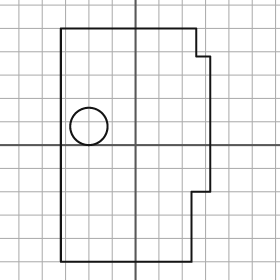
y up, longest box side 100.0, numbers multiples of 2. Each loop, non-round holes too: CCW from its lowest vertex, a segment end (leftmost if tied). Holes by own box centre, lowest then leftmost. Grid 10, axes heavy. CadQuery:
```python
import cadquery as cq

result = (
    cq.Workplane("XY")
    .moveTo(-32.0, -50.0)
    .lineTo(24.0, -50.0)
    .lineTo(24.0, -20.0)
    .lineTo(32.0, -20.0)
    .lineTo(32.0, 38.0)
    .lineTo(26.0, 38.0)
    .lineTo(26.0, 50.0)
    .lineTo(-32.0, 50.0)
    .close()
    .moveTo(-20.0, 8.0)
    .circle(8.0)
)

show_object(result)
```